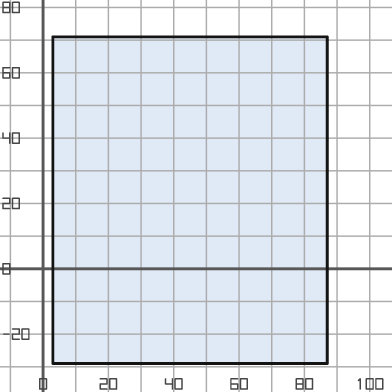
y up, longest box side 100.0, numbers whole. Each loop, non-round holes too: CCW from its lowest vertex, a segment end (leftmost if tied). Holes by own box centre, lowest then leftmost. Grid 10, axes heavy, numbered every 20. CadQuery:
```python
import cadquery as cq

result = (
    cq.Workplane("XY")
    .moveTo(3.0, -29.0)
    .lineTo(87.0, -29.0)
    .lineTo(87.0, 71.0)
    .lineTo(3.0, 71.0)
    .close()
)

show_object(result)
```